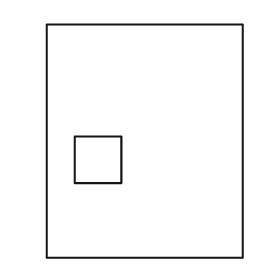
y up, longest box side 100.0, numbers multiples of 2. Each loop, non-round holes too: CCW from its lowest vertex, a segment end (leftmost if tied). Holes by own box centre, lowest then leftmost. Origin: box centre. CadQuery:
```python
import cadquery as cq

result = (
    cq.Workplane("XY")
    .moveTo(-42.0, -50.0)
    .lineTo(42.0, -50.0)
    .lineTo(42.0, 50.0)
    .lineTo(-42.0, 50.0)
    .close()
    .moveTo(-30.0, -18.0)
    .lineTo(-10.0, -18.0)
    .lineTo(-10.0, 2.0)
    .lineTo(-30.0, 2.0)
    .close()
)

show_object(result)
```